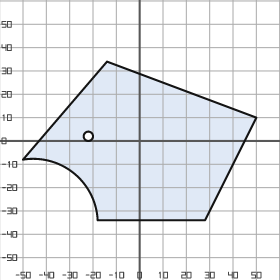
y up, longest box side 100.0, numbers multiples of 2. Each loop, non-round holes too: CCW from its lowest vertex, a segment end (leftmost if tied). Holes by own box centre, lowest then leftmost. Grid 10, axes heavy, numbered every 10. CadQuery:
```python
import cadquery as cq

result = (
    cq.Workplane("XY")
    .moveTo(-18.0, -34.0)
    .lineTo(28.0, -34.0)
    .lineTo(50.0, 10.0)
    .lineTo(-14.0, 34.0)
    .lineTo(-50.0, -8.0)
    .threePointArc((-28.0, -14.0), (-18.0, -34.0))
    .close()
    .moveTo(-22.0, 2.0)
    .circle(2.0)
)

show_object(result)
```